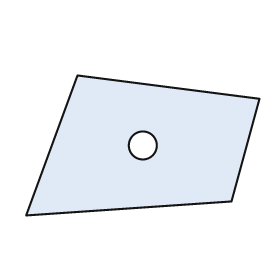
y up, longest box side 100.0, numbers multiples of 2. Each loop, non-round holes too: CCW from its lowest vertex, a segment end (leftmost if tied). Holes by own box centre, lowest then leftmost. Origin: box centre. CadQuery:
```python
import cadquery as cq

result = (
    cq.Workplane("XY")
    .moveTo(-50.0, -30.0)
    .lineTo(38.0, -24.0)
    .lineTo(50.0, 20.0)
    .lineTo(-28.0, 30.0)
    .close()
    .moveTo(0.0, 0.0)
    .circle(6.0)
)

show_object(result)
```